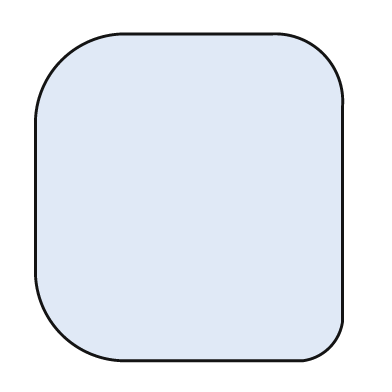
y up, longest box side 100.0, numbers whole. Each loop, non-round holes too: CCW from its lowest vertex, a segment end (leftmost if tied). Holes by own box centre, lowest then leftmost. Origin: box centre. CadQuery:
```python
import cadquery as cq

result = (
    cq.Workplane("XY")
    .moveTo(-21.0, -50.0)
    .lineTo(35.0, -50.0)
    .threePointArc((43.0, -46.0), (47.0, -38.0))
    .lineTo(47.0, 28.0)
    .threePointArc((41.0, 44.0), (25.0, 50.0))
    .lineTo(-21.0, 50.0)
    .threePointArc((-39.0, 42.0), (-47.0, 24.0))
    .lineTo(-47.0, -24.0)
    .threePointArc((-39.0, -42.0), (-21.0, -50.0))
    .close()
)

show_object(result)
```